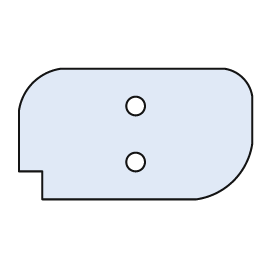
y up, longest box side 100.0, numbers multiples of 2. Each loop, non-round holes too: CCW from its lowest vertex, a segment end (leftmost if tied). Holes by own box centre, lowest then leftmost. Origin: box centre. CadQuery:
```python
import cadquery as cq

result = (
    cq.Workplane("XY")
    .moveTo(-40.0, -28.0)
    .lineTo(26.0, -28.0)
    .threePointArc((42.0, -20.0), (50.0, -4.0))
    .lineTo(50.0, 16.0)
    .threePointArc((46.0, 24.0), (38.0, 28.0))
    .lineTo(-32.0, 28.0)
    .threePointArc((-44.0, 22.0), (-50.0, 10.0))
    .lineTo(-50.0, -16.0)
    .lineTo(-40.0, -16.0)
    .close()
    .moveTo(0.0, -12.0)
    .circle(4.0)
    .moveTo(0.0, 12.0)
    .circle(4.0)
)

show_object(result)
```